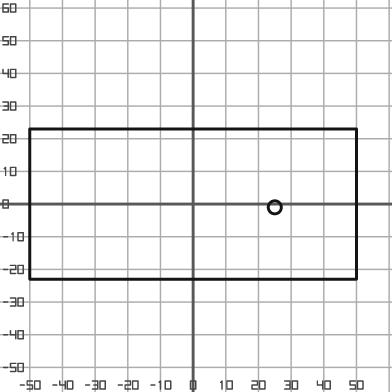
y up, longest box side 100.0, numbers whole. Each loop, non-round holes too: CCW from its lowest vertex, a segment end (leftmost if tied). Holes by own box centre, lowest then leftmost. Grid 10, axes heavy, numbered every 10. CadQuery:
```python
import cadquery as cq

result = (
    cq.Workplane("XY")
    .moveTo(-50.0, -23.0)
    .lineTo(50.0, -23.0)
    .lineTo(50.0, 23.0)
    .lineTo(-50.0, 23.0)
    .close()
    .moveTo(25.0, -1.0)
    .circle(2.0)
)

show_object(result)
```